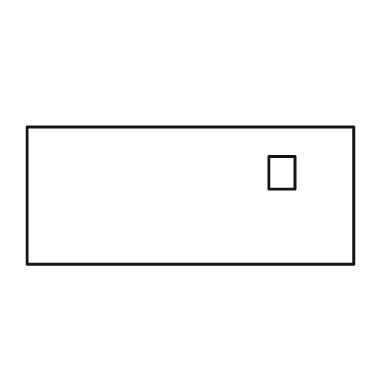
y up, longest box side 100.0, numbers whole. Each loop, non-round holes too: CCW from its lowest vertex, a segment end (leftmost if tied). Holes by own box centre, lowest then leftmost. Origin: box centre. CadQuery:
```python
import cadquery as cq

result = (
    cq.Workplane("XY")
    .moveTo(-50.0, -21.0)
    .lineTo(50.0, -21.0)
    .lineTo(50.0, 21.0)
    .lineTo(-50.0, 21.0)
    .close()
    .moveTo(24.0, 2.0)
    .lineTo(32.0, 2.0)
    .lineTo(32.0, 12.0)
    .lineTo(24.0, 12.0)
    .close()
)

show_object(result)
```